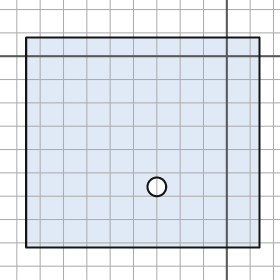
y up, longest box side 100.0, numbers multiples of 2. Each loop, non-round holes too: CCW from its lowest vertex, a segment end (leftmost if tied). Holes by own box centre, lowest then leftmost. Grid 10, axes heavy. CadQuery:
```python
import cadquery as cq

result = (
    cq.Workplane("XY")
    .moveTo(-86.0, -82.0)
    .lineTo(14.0, -82.0)
    .lineTo(14.0, 8.0)
    .lineTo(-86.0, 8.0)
    .close()
    .moveTo(-30.0, -56.0)
    .circle(4.0)
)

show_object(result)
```